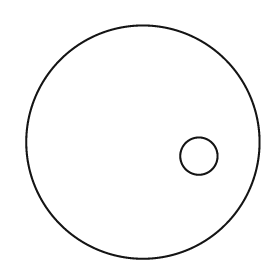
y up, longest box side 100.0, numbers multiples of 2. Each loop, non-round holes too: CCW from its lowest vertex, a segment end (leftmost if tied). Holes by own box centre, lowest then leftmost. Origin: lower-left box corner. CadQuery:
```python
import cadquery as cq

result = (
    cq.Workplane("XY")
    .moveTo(50.0, 50.0)
    .circle(50.0)
    .moveTo(74.0, 44.0)
    .circle(8.0)
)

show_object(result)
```